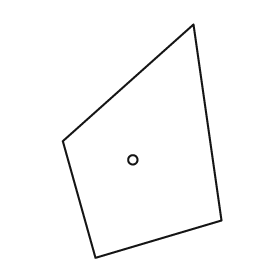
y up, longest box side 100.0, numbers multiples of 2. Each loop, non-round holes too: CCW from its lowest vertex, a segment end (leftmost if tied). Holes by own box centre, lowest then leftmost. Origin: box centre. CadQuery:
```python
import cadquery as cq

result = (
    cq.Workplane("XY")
    .moveTo(-20.0, -50.0)
    .lineTo(34.0, -34.0)
    .lineTo(22.0, 50.0)
    .lineTo(-34.0, 0.0)
    .close()
    .moveTo(-4.0, -8.0)
    .circle(2.0)
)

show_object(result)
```